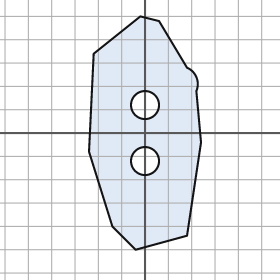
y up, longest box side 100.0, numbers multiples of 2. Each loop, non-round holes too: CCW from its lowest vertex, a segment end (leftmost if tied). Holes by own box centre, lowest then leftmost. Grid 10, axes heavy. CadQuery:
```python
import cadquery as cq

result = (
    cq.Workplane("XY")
    .moveTo(-4.0, -50.0)
    .lineTo(18.0, -44.0)
    .lineTo(24.0, -4.0)
    .lineTo(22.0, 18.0)
    .threePointArc((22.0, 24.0), (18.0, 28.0))
    .lineTo(6.0, 48.0)
    .lineTo(-2.0, 50.0)
    .lineTo(-22.0, 34.0)
    .lineTo(-24.0, -8.0)
    .lineTo(-14.0, -40.0)
    .close()
    .moveTo(0.0, -12.0)
    .circle(6.0)
    .moveTo(0.0, 12.0)
    .circle(6.0)
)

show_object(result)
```